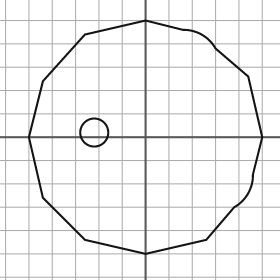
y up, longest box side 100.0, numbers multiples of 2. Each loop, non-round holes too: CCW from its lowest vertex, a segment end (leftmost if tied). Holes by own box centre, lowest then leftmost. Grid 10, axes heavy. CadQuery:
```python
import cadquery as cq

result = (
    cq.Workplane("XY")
    .moveTo(0.0, -50.0)
    .lineTo(26.0, -44.0)
    .lineTo(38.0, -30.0)
    .threePointArc((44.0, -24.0), (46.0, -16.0))
    .lineTo(50.0, 0.0)
    .lineTo(44.0, 26.0)
    .lineTo(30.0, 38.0)
    .threePointArc((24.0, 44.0), (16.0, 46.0))
    .lineTo(0.0, 50.0)
    .lineTo(-26.0, 44.0)
    .lineTo(-44.0, 24.0)
    .lineTo(-50.0, 0.0)
    .lineTo(-44.0, -26.0)
    .lineTo(-26.0, -44.0)
    .close()
    .moveTo(-22.0, 2.0)
    .circle(6.0)
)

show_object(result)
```